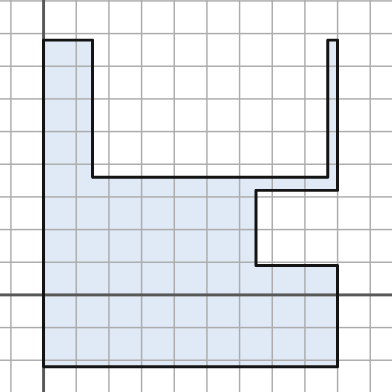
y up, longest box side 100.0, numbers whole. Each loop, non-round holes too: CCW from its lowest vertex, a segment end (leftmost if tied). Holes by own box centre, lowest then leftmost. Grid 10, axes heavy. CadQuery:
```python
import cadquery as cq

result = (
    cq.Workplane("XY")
    .moveTo(0.0, -22.0)
    .lineTo(90.0, -22.0)
    .lineTo(90.0, 9.0)
    .lineTo(65.0, 9.0)
    .lineTo(65.0, 32.0)
    .lineTo(90.0, 32.0)
    .lineTo(90.0, 78.0)
    .lineTo(87.0, 78.0)
    .lineTo(87.0, 36.0)
    .lineTo(15.0, 36.0)
    .lineTo(15.0, 78.0)
    .lineTo(0.0, 78.0)
    .close()
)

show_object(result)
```